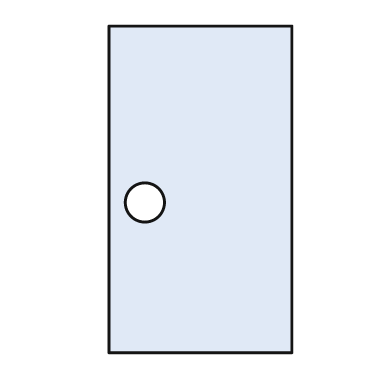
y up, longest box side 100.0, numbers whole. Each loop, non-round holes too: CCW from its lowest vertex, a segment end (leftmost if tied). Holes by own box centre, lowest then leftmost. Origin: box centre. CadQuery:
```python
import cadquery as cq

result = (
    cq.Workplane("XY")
    .moveTo(-28.0, -50.0)
    .lineTo(28.0, -50.0)
    .lineTo(28.0, 50.0)
    .lineTo(-28.0, 50.0)
    .close()
    .moveTo(-17.0, -4.0)
    .circle(6.0)
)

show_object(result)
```